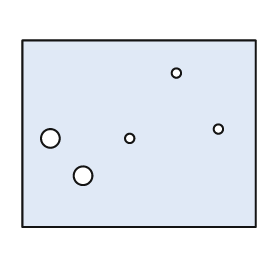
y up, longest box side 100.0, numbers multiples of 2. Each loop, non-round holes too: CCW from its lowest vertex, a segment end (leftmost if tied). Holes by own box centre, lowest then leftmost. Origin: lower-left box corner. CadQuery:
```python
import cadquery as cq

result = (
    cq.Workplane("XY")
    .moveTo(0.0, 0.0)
    .lineTo(100.0, 0.0)
    .lineTo(100.0, 80.0)
    .lineTo(0.0, 80.0)
    .close()
    .moveTo(26.0, 22.0)
    .circle(4.0)
    .moveTo(12.0, 38.0)
    .circle(4.0)
    .moveTo(46.0, 38.0)
    .circle(2.0)
    .moveTo(84.0, 42.0)
    .circle(2.0)
    .moveTo(66.0, 66.0)
    .circle(2.0)
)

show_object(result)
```